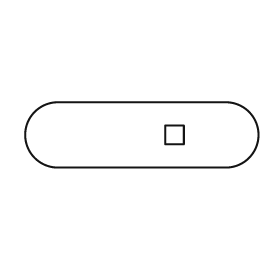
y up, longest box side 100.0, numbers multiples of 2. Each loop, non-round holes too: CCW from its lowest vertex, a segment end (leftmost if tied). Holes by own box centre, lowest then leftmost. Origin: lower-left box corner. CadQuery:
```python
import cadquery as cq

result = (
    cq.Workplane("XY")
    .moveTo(14.0, 0.0)
    .lineTo(86.0, 0.0)
    .threePointArc((100.0, 14.0), (86.0, 28.0))
    .lineTo(14.0, 28.0)
    .threePointArc((0.0, 14.0), (14.0, 0.0))
    .close()
    .moveTo(60.0, 10.0)
    .lineTo(68.0, 10.0)
    .lineTo(68.0, 18.0)
    .lineTo(60.0, 18.0)
    .close()
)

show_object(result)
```